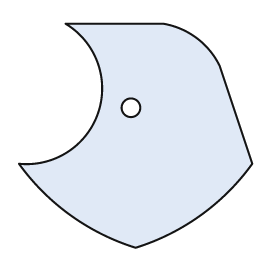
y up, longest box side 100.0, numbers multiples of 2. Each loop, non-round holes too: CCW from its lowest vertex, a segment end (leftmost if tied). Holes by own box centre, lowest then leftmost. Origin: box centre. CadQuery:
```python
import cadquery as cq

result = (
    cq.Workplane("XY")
    .moveTo(0.0, -48.0)
    .threePointArc((28.0, -34.0), (50.0, -12.0))
    .lineTo(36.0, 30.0)
    .threePointArc((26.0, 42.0), (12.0, 48.0))
    .lineTo(-30.0, 48.0)
    .threePointArc((-16.0, 10.0), (-50.0, -12.0))
    .threePointArc((-28.0, -34.0), (0.0, -48.0))
    .close()
    .moveTo(-2.0, 12.0)
    .circle(4.0)
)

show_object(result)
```